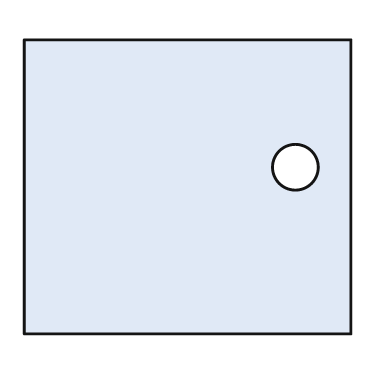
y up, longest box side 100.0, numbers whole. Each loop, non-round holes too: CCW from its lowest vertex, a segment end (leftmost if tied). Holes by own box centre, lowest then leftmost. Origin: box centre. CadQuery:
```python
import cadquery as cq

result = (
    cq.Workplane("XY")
    .moveTo(-50.0, -45.0)
    .lineTo(50.0, -45.0)
    .lineTo(50.0, 45.0)
    .lineTo(-50.0, 45.0)
    .close()
    .moveTo(33.0, 6.0)
    .circle(7.0)
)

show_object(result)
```